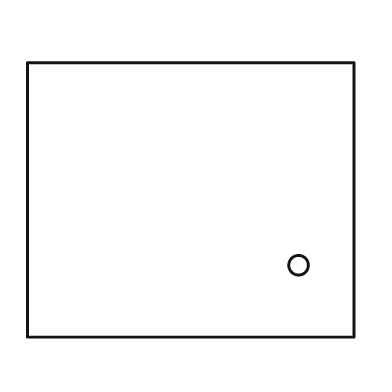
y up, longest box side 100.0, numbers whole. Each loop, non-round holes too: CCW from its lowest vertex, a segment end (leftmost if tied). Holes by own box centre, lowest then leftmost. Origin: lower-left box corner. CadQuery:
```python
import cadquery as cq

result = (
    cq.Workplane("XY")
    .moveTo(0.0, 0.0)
    .lineTo(100.0, 0.0)
    .lineTo(100.0, 84.0)
    .lineTo(0.0, 84.0)
    .close()
    .moveTo(83.0, 22.0)
    .circle(3.0)
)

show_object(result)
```